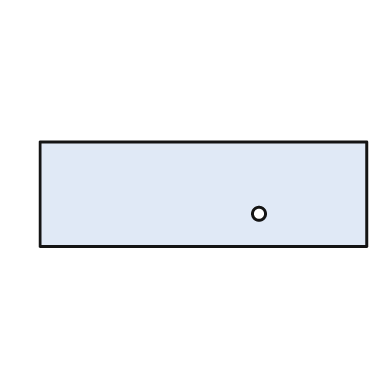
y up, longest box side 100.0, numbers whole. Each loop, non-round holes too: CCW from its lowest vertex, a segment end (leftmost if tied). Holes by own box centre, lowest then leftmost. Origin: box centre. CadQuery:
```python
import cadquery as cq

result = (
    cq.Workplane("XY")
    .moveTo(-50.0, -16.0)
    .lineTo(50.0, -16.0)
    .lineTo(50.0, 16.0)
    .lineTo(-50.0, 16.0)
    .close()
    .moveTo(17.0, -6.0)
    .circle(2.0)
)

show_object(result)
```